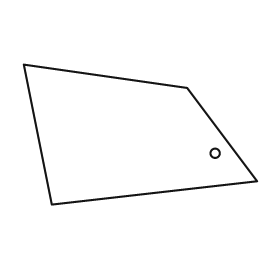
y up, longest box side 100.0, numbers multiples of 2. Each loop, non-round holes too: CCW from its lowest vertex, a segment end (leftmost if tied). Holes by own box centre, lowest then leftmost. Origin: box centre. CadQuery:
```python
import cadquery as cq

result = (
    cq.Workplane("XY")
    .moveTo(-38.0, -30.0)
    .lineTo(50.0, -20.0)
    .lineTo(20.0, 20.0)
    .lineTo(-50.0, 30.0)
    .close()
    .moveTo(32.0, -8.0)
    .circle(2.0)
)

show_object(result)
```